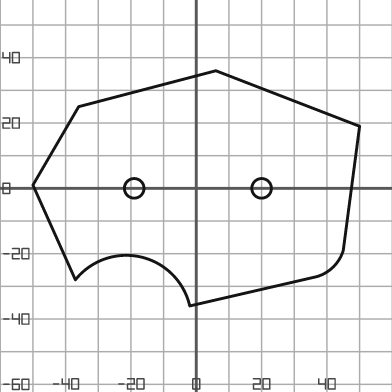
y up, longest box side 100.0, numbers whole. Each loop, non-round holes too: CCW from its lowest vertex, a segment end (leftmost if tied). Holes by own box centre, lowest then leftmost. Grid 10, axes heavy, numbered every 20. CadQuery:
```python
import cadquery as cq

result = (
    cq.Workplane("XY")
    .moveTo(-2.0, -36.0)
    .lineTo(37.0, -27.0)
    .threePointArc((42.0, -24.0), (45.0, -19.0))
    .lineTo(50.0, 19.0)
    .lineTo(6.0, 36.0)
    .lineTo(-36.0, 25.0)
    .lineTo(-50.0, 1.0)
    .lineTo(-37.0, -28.0)
    .threePointArc((-17.0, -21.0), (-2.0, -36.0))
    .close()
    .moveTo(-19.0, 0.0)
    .circle(3.0)
    .moveTo(20.0, 0.0)
    .circle(3.0)
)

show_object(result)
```